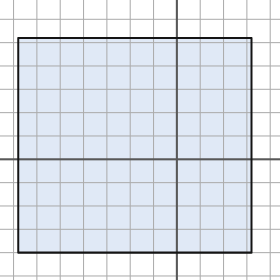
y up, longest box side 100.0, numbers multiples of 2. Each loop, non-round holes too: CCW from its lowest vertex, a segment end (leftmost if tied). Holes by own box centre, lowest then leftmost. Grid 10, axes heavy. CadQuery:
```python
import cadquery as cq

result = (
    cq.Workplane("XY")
    .moveTo(-68.0, -40.0)
    .lineTo(32.0, -40.0)
    .lineTo(32.0, 52.0)
    .lineTo(-68.0, 52.0)
    .close()
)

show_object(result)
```